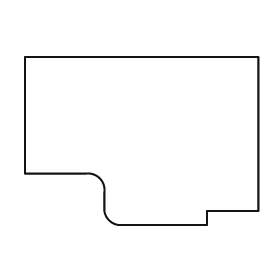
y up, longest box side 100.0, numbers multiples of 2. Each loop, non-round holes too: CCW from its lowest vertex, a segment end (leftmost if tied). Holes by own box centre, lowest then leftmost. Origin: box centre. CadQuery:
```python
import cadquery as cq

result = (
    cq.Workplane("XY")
    .moveTo(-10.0, -36.0)
    .lineTo(28.0, -36.0)
    .lineTo(28.0, -30.0)
    .lineTo(50.0, -30.0)
    .lineTo(50.0, 36.0)
    .lineTo(-50.0, 36.0)
    .lineTo(-50.0, -14.0)
    .lineTo(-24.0, -14.0)
    .threePointArc((-18.0, -16.0), (-16.0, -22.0))
    .lineTo(-16.0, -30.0)
    .threePointArc((-14.0, -34.0), (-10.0, -36.0))
    .close()
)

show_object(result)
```